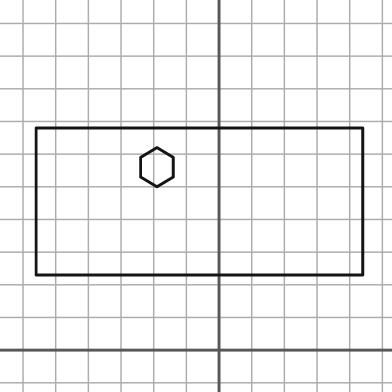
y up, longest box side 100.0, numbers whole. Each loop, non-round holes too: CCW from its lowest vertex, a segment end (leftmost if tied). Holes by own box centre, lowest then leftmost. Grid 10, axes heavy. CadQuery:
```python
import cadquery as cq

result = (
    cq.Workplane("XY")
    .moveTo(-56.0, 23.0)
    .lineTo(44.0, 23.0)
    .lineTo(44.0, 68.0)
    .lineTo(-56.0, 68.0)
    .close()
    .moveTo(-19.0, 50.0)
    .lineTo(-14.0, 53.0)
    .lineTo(-14.0, 59.0)
    .lineTo(-19.0, 62.0)
    .lineTo(-24.0, 59.0)
    .lineTo(-24.0, 53.0)
    .close()
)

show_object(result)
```